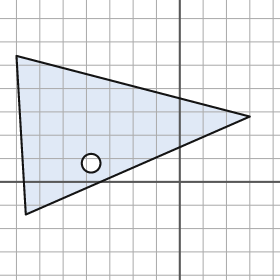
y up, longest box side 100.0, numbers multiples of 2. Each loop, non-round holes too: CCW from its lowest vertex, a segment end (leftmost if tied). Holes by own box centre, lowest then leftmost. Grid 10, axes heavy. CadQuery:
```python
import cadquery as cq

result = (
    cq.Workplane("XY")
    .moveTo(-66.0, -14.0)
    .lineTo(30.0, 28.0)
    .lineTo(-70.0, 54.0)
    .close()
    .moveTo(-38.0, 8.0)
    .circle(4.0)
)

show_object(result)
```